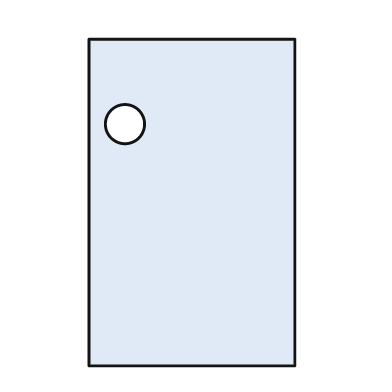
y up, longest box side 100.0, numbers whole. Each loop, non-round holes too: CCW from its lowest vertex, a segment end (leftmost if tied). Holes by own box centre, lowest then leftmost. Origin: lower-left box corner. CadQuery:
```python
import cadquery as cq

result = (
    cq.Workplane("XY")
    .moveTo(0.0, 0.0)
    .lineTo(63.0, 0.0)
    .lineTo(63.0, 100.0)
    .lineTo(0.0, 100.0)
    .close()
    .moveTo(11.0, 74.0)
    .circle(6.0)
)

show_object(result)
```